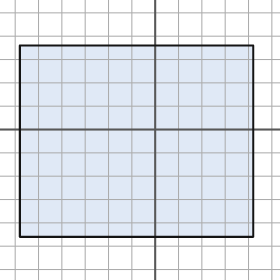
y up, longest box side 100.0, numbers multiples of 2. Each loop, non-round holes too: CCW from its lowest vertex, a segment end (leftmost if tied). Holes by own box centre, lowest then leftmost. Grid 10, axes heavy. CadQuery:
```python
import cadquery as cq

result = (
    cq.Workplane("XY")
    .moveTo(-58.0, -46.0)
    .lineTo(42.0, -46.0)
    .lineTo(42.0, 36.0)
    .lineTo(-58.0, 36.0)
    .close()
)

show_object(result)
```